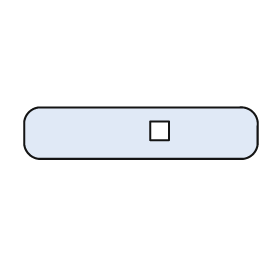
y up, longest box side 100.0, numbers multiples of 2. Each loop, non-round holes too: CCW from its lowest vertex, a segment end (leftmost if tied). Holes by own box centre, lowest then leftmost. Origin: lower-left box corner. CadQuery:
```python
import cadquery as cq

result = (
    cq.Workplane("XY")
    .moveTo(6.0, 0.0)
    .lineTo(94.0, 0.0)
    .threePointArc((98.0, 2.0), (100.0, 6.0))
    .lineTo(100.0, 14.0)
    .threePointArc((98.0, 20.0), (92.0, 22.0))
    .lineTo(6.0, 22.0)
    .threePointArc((2.0, 20.0), (0.0, 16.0))
    .lineTo(0.0, 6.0)
    .threePointArc((2.0, 2.0), (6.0, 0.0))
    .close()
    .moveTo(54.0, 8.0)
    .lineTo(62.0, 8.0)
    .lineTo(62.0, 16.0)
    .lineTo(54.0, 16.0)
    .close()
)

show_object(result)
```